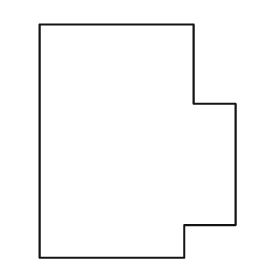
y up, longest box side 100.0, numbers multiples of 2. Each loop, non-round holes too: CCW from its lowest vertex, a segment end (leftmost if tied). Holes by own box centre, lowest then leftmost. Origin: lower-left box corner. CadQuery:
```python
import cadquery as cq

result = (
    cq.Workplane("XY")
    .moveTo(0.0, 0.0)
    .lineTo(62.0, 0.0)
    .lineTo(62.0, 14.0)
    .lineTo(84.0, 14.0)
    .lineTo(84.0, 66.0)
    .lineTo(66.0, 66.0)
    .lineTo(66.0, 100.0)
    .lineTo(0.0, 100.0)
    .close()
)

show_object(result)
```